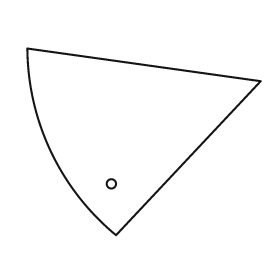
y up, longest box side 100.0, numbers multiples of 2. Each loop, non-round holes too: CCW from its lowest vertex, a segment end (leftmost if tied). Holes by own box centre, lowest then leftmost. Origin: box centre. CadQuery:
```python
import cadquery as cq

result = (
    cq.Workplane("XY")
    .moveTo(-12.0, -40.0)
    .lineTo(50.0, 26.0)
    .lineTo(-50.0, 40.0)
    .threePointArc((-40.0, -4.0), (-12.0, -40.0))
    .close()
    .moveTo(-14.0, -18.0)
    .circle(2.0)
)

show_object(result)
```